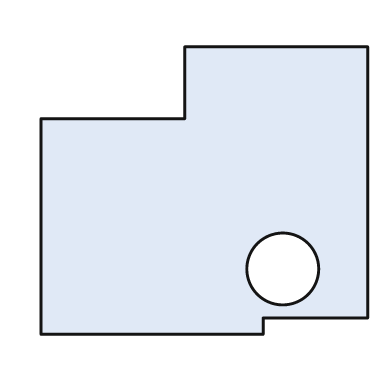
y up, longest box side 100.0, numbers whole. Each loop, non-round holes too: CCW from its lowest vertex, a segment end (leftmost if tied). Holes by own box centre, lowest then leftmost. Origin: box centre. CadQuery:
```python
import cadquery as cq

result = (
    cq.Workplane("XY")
    .moveTo(-50.0, -44.0)
    .lineTo(18.0, -44.0)
    .lineTo(18.0, -39.0)
    .lineTo(50.0, -39.0)
    .lineTo(50.0, 44.0)
    .lineTo(-6.0, 44.0)
    .lineTo(-6.0, 22.0)
    .lineTo(-50.0, 22.0)
    .close()
    .moveTo(24.0, -24.0)
    .circle(11.0)
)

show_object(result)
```